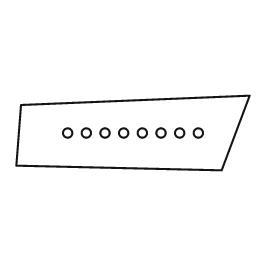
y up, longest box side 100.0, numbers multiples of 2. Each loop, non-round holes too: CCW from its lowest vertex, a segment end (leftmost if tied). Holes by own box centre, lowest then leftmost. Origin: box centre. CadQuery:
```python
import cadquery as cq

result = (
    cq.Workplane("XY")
    .moveTo(38.0, -16.0)
    .lineTo(50.0, 16.0)
    .lineTo(-48.0, 12.0)
    .lineTo(-50.0, -14.0)
    .close()
    .moveTo(-28.0, 0.0)
    .circle(2.0)
    .moveTo(-20.0, 0.0)
    .circle(2.0)
    .moveTo(-12.0, 0.0)
    .circle(2.0)
    .moveTo(-4.0, 0.0)
    .circle(2.0)
    .moveTo(4.0, 0.0)
    .circle(2.0)
    .moveTo(12.0, 0.0)
    .circle(2.0)
    .moveTo(20.0, 0.0)
    .circle(2.0)
    .moveTo(28.0, 0.0)
    .circle(2.0)
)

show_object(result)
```